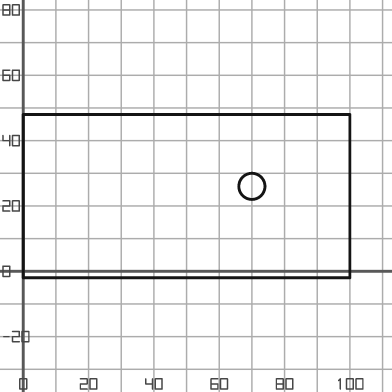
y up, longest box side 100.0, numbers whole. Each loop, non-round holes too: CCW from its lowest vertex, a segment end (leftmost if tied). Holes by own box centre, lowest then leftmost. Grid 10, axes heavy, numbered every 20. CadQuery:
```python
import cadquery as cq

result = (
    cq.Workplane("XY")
    .moveTo(0.0, -2.0)
    .lineTo(100.0, -2.0)
    .lineTo(100.0, 48.0)
    .lineTo(0.0, 48.0)
    .close()
    .moveTo(70.0, 26.0)
    .circle(4.0)
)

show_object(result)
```